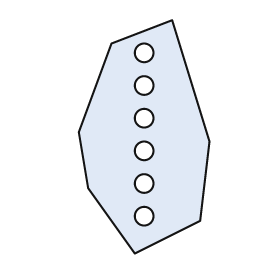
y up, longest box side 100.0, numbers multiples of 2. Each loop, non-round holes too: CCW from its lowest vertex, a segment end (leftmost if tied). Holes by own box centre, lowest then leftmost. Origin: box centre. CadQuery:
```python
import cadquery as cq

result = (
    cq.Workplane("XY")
    .moveTo(-4.0, -50.0)
    .lineTo(24.0, -36.0)
    .lineTo(28.0, -2.0)
    .lineTo(12.0, 50.0)
    .lineTo(-14.0, 40.0)
    .lineTo(-28.0, 2.0)
    .lineTo(-24.0, -22.0)
    .close()
    .moveTo(0.0, -34.0)
    .circle(4.0)
    .moveTo(0.0, -20.0)
    .circle(4.0)
    .moveTo(0.0, -6.0)
    .circle(4.0)
    .moveTo(0.0, 8.0)
    .circle(4.0)
    .moveTo(0.0, 22.0)
    .circle(4.0)
    .moveTo(0.0, 36.0)
    .circle(4.0)
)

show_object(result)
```